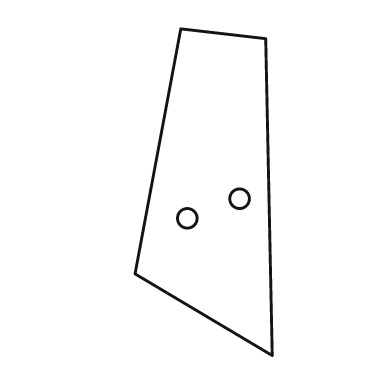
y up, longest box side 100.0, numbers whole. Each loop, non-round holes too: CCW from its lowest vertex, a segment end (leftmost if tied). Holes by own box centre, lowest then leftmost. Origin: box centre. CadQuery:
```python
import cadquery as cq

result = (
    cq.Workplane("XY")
    .moveTo(21.0, -50.0)
    .lineTo(19.0, 47.0)
    .lineTo(-7.0, 50.0)
    .lineTo(-21.0, -25.0)
    .close()
    .moveTo(-5.0, -8.0)
    .circle(3.0)
    .moveTo(11.0, -2.0)
    .circle(3.0)
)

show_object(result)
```